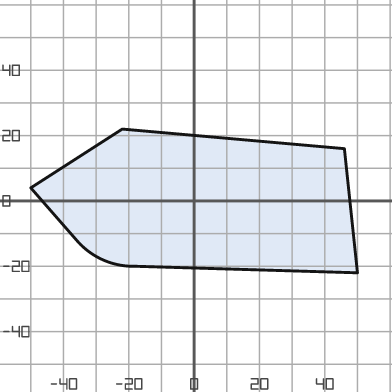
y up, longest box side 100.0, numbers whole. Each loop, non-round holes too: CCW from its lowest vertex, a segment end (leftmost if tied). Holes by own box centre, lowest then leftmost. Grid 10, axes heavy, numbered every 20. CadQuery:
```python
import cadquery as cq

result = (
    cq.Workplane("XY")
    .moveTo(50.0, -22.0)
    .lineTo(46.0, 16.0)
    .lineTo(-22.0, 22.0)
    .lineTo(-50.0, 4.0)
    .lineTo(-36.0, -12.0)
    .threePointArc((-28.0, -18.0), (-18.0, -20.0))
    .close()
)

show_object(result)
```